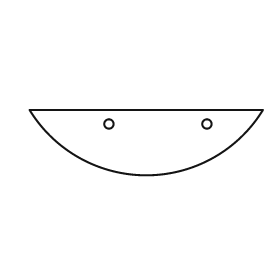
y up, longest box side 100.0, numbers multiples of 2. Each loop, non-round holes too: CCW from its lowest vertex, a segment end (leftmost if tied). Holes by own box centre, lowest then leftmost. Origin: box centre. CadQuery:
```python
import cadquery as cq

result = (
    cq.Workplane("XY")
    .moveTo(-50.0, 14.0)
    .threePointArc((0.0, -14.0), (50.0, 14.0))
    .close()
    .moveTo(-16.0, 8.0)
    .circle(2.0)
    .moveTo(26.0, 8.0)
    .circle(2.0)
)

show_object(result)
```